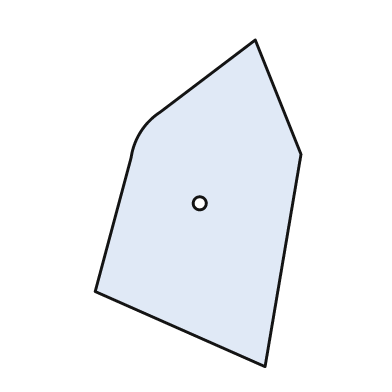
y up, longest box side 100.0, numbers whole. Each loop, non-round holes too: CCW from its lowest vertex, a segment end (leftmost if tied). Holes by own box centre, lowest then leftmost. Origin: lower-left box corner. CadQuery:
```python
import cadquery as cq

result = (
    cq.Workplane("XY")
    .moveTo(52.0, 0.0)
    .lineTo(63.0, 65.0)
    .lineTo(49.0, 100.0)
    .lineTo(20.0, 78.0)
    .threePointArc((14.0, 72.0), (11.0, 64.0))
    .lineTo(0.0, 23.0)
    .close()
    .moveTo(32.0, 50.0)
    .circle(2.0)
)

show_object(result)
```